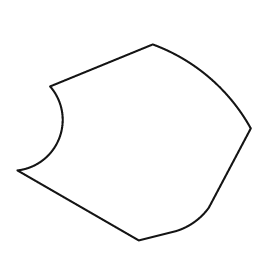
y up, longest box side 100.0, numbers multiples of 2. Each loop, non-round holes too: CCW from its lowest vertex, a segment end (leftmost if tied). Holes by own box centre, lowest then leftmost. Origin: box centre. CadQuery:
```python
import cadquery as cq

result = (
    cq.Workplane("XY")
    .moveTo(2.0, -42.0)
    .lineTo(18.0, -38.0)
    .threePointArc((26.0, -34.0), (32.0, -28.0))
    .lineTo(50.0, 6.0)
    .threePointArc((32.0, 28.0), (8.0, 42.0))
    .lineTo(-36.0, 24.0)
    .threePointArc((-32.0, 2.0), (-50.0, -12.0))
    .close()
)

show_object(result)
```